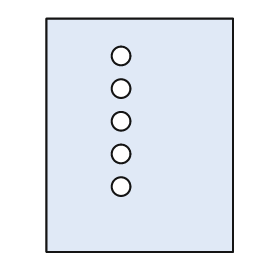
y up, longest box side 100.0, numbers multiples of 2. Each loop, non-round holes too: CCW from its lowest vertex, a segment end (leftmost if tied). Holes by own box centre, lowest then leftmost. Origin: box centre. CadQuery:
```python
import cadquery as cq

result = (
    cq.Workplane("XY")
    .moveTo(-40.0, -50.0)
    .lineTo(40.0, -50.0)
    .lineTo(40.0, 50.0)
    .lineTo(-40.0, 50.0)
    .close()
    .moveTo(-8.0, -22.0)
    .circle(4.0)
    .moveTo(-8.0, -8.0)
    .circle(4.0)
    .moveTo(-8.0, 6.0)
    .circle(4.0)
    .moveTo(-8.0, 20.0)
    .circle(4.0)
    .moveTo(-8.0, 34.0)
    .circle(4.0)
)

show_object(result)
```